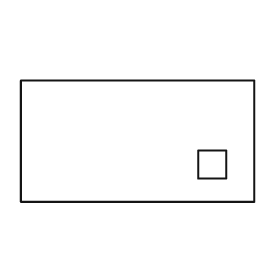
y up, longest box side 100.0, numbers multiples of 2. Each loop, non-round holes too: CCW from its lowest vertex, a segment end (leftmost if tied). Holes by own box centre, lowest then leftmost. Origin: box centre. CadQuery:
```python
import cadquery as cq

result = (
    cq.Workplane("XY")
    .moveTo(-50.0, -26.0)
    .lineTo(50.0, -26.0)
    .lineTo(50.0, 26.0)
    .lineTo(-50.0, 26.0)
    .close()
    .moveTo(26.0, -16.0)
    .lineTo(38.0, -16.0)
    .lineTo(38.0, -4.0)
    .lineTo(26.0, -4.0)
    .close()
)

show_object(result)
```